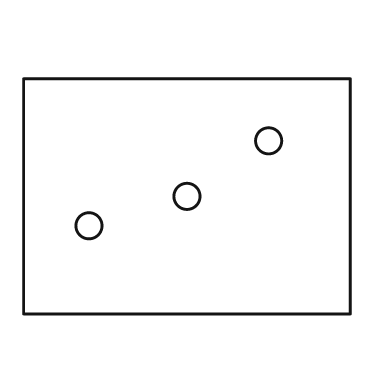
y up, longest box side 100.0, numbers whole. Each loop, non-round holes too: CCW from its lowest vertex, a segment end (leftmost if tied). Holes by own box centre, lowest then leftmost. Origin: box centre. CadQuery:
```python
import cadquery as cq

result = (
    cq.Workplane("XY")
    .moveTo(-50.0, -36.0)
    .lineTo(50.0, -36.0)
    .lineTo(50.0, 36.0)
    .lineTo(-50.0, 36.0)
    .close()
    .moveTo(-30.0, -9.0)
    .circle(4.0)
    .moveTo(0.0, 0.0)
    .circle(4.0)
    .moveTo(25.0, 17.0)
    .circle(4.0)
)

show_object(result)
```